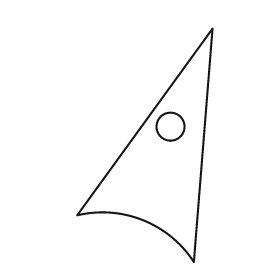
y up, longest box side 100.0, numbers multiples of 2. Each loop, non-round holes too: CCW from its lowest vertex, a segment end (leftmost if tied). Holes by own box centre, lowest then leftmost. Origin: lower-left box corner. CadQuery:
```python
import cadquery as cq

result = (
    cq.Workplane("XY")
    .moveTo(50.0, 0.0)
    .lineTo(58.0, 100.0)
    .lineTo(0.0, 20.0)
    .threePointArc((28.0, 18.0), (50.0, 0.0))
    .close()
    .moveTo(40.0, 58.0)
    .circle(6.0)
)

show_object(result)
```